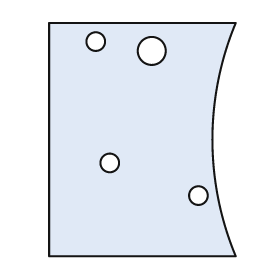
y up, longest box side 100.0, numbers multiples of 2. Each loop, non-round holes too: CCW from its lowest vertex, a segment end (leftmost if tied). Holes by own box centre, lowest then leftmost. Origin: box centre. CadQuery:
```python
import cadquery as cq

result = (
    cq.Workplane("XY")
    .moveTo(-40.0, -50.0)
    .lineTo(40.0, -50.0)
    .threePointArc((30.0, 0.0), (40.0, 50.0))
    .lineTo(-40.0, 50.0)
    .close()
    .moveTo(24.0, -24.0)
    .circle(4.0)
    .moveTo(-14.0, -10.0)
    .circle(4.0)
    .moveTo(4.0, 38.0)
    .circle(6.0)
    .moveTo(-20.0, 42.0)
    .circle(4.0)
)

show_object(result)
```